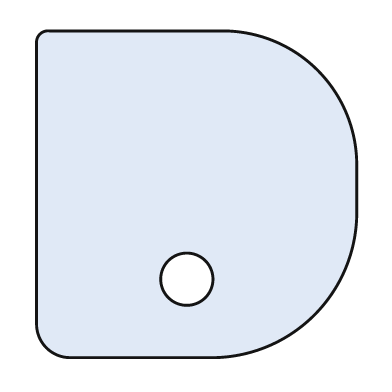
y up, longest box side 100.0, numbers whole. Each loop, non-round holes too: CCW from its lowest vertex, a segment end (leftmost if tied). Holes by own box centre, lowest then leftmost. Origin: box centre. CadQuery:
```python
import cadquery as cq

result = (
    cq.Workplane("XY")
    .moveTo(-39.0, -50.0)
    .lineTo(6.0, -50.0)
    .threePointArc((36.0, -37.0), (49.0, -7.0))
    .lineTo(49.0, 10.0)
    .threePointArc((37.0, 38.0), (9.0, 50.0))
    .lineTo(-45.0, 50.0)
    .threePointArc((-48.0, 49.0), (-49.0, 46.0))
    .lineTo(-49.0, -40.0)
    .threePointArc((-46.0, -47.0), (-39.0, -50.0))
    .close()
    .moveTo(-3.0, -26.0)
    .circle(8.0)
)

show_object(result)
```